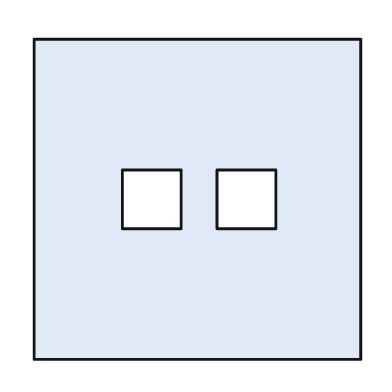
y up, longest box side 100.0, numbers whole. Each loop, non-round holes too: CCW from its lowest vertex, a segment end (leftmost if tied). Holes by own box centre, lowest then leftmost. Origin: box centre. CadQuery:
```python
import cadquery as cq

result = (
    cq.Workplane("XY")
    .moveTo(-50.0, -49.0)
    .lineTo(50.0, -49.0)
    .lineTo(50.0, 49.0)
    .lineTo(-50.0, 49.0)
    .close()
    .moveTo(-23.0, -9.0)
    .lineTo(-5.0, -9.0)
    .lineTo(-5.0, 9.0)
    .lineTo(-23.0, 9.0)
    .close()
    .moveTo(6.0, -9.0)
    .lineTo(24.0, -9.0)
    .lineTo(24.0, 9.0)
    .lineTo(6.0, 9.0)
    .close()
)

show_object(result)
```